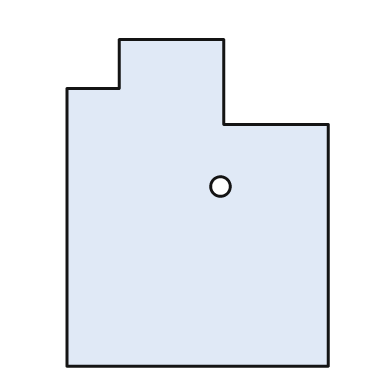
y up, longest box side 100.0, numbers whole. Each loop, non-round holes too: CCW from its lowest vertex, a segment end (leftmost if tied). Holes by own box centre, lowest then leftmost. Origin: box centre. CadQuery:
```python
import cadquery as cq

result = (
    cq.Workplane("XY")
    .moveTo(-40.0, -50.0)
    .lineTo(40.0, -50.0)
    .lineTo(40.0, 24.0)
    .lineTo(8.0, 24.0)
    .lineTo(8.0, 50.0)
    .lineTo(-24.0, 50.0)
    .lineTo(-24.0, 35.0)
    .lineTo(-40.0, 35.0)
    .close()
    .moveTo(7.0, 5.0)
    .circle(3.0)
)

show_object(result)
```